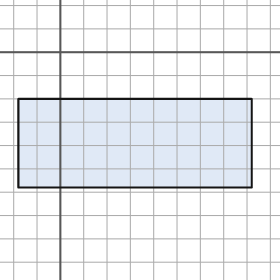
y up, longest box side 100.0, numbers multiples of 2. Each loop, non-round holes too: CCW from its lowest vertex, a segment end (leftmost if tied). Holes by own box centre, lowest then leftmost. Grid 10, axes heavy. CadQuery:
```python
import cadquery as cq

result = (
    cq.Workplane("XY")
    .moveTo(-18.0, -58.0)
    .lineTo(82.0, -58.0)
    .lineTo(82.0, -20.0)
    .lineTo(-18.0, -20.0)
    .close()
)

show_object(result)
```